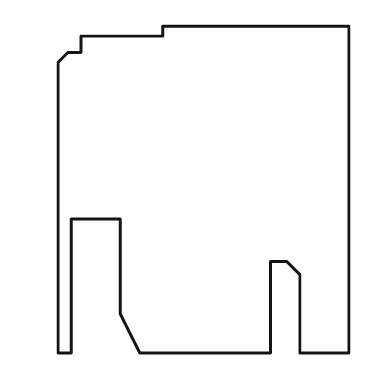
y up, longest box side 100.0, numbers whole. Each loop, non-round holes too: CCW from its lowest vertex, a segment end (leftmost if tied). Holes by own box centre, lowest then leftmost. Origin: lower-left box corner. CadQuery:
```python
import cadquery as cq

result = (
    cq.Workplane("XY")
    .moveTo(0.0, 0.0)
    .lineTo(4.0, 0.0)
    .lineTo(4.0, 41.0)
    .lineTo(19.0, 41.0)
    .lineTo(19.0, 12.0)
    .lineTo(25.0, 0.0)
    .lineTo(65.0, 0.0)
    .lineTo(65.0, 28.0)
    .lineTo(70.0, 28.0)
    .lineTo(74.0, 24.0)
    .lineTo(74.0, 0.0)
    .lineTo(89.0, 0.0)
    .lineTo(89.0, 100.0)
    .lineTo(32.0, 100.0)
    .lineTo(32.0, 97.0)
    .lineTo(7.0, 97.0)
    .lineTo(7.0, 92.0)
    .lineTo(3.0, 92.0)
    .lineTo(0.0, 89.0)
    .close()
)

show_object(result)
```